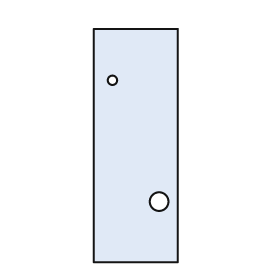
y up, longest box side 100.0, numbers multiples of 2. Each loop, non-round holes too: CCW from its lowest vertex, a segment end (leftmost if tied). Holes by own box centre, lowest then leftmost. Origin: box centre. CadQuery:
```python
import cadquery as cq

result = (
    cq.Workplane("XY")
    .moveTo(-18.0, -50.0)
    .lineTo(18.0, -50.0)
    .lineTo(18.0, 50.0)
    .lineTo(-18.0, 50.0)
    .close()
    .moveTo(10.0, -24.0)
    .circle(4.0)
    .moveTo(-10.0, 28.0)
    .circle(2.0)
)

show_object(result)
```